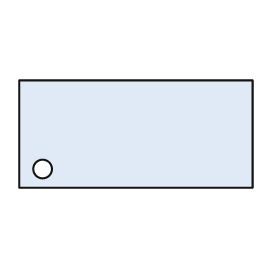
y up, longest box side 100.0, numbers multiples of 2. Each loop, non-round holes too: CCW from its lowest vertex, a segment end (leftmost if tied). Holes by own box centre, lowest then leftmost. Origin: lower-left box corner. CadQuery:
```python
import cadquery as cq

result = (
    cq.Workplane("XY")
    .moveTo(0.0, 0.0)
    .lineTo(100.0, 0.0)
    .lineTo(100.0, 46.0)
    .lineTo(0.0, 46.0)
    .close()
    .moveTo(10.0, 8.0)
    .circle(4.0)
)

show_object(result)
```